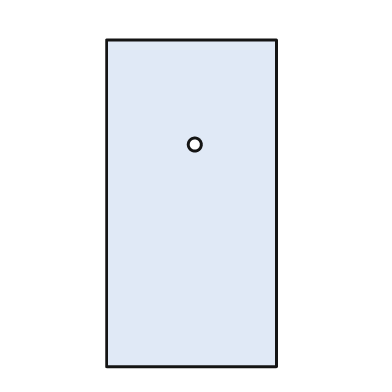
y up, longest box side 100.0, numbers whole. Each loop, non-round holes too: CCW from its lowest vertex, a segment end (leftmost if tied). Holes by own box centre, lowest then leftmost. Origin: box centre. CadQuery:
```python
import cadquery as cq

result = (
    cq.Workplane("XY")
    .moveTo(-26.0, -50.0)
    .lineTo(26.0, -50.0)
    .lineTo(26.0, 50.0)
    .lineTo(-26.0, 50.0)
    .close()
    .moveTo(1.0, 18.0)
    .circle(2.0)
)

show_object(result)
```